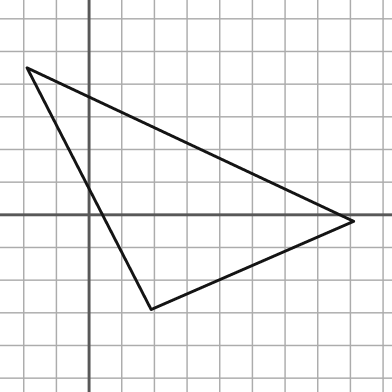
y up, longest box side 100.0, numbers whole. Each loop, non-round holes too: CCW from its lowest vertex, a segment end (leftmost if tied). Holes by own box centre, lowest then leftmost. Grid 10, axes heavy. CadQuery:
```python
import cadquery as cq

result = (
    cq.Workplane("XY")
    .moveTo(19.0, -29.0)
    .lineTo(81.0, -2.0)
    .lineTo(-19.0, 45.0)
    .close()
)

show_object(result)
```